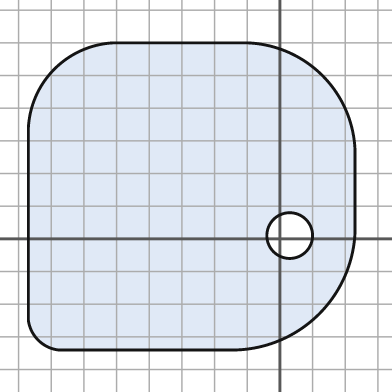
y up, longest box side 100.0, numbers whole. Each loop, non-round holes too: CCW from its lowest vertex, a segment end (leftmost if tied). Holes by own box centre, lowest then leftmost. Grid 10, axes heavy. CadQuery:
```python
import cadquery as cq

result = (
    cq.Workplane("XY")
    .moveTo(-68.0, -34.0)
    .lineTo(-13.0, -34.0)
    .threePointArc((12.0, -23.0), (23.0, 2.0))
    .lineTo(23.0, 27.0)
    .threePointArc((13.0, 50.0), (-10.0, 60.0))
    .lineTo(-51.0, 60.0)
    .threePointArc((-69.0, 52.0), (-77.0, 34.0))
    .lineTo(-77.0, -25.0)
    .threePointArc((-74.0, -31.0), (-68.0, -34.0))
    .close()
    .moveTo(3.0, 1.0)
    .circle(7.0)
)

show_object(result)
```